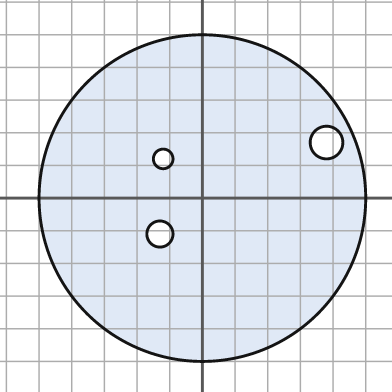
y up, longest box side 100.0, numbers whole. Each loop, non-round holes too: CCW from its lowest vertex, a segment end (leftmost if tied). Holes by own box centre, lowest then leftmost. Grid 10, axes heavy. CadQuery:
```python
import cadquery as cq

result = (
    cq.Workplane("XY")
    .moveTo(0.0, 0.0)
    .circle(50.0)
    .moveTo(-13.0, -11.0)
    .circle(4.0)
    .moveTo(-12.0, 12.0)
    .circle(3.0)
    .moveTo(38.0, 17.0)
    .circle(5.0)
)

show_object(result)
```